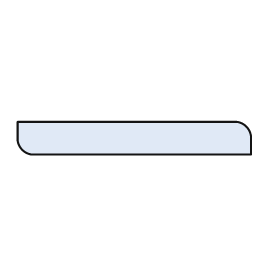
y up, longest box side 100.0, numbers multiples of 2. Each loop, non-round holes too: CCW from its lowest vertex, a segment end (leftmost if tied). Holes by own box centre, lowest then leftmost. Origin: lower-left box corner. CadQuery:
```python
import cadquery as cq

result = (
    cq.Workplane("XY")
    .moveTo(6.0, 0.0)
    .lineTo(100.0, 0.0)
    .lineTo(100.0, 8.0)
    .threePointArc((98.0, 12.0), (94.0, 14.0))
    .lineTo(0.0, 14.0)
    .lineTo(0.0, 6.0)
    .threePointArc((2.0, 2.0), (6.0, 0.0))
    .close()
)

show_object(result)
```